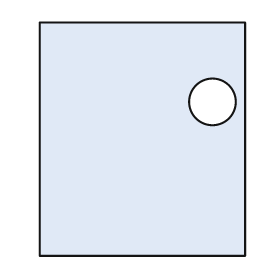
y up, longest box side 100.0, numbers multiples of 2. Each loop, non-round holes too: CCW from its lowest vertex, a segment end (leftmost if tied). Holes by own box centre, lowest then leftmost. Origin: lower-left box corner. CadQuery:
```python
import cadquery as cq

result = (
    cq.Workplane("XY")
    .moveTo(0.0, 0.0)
    .lineTo(88.0, 0.0)
    .lineTo(88.0, 100.0)
    .lineTo(0.0, 100.0)
    .close()
    .moveTo(74.0, 66.0)
    .circle(10.0)
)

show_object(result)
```